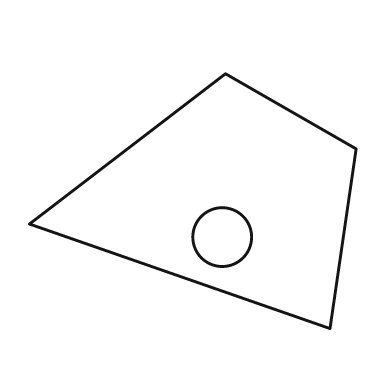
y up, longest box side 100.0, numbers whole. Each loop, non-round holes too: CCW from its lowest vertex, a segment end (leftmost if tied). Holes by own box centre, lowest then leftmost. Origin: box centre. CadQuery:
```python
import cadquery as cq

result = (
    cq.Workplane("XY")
    .moveTo(42.0, -39.0)
    .lineTo(50.0, 16.0)
    .lineTo(10.0, 39.0)
    .lineTo(-50.0, -7.0)
    .close()
    .moveTo(9.0, -11.0)
    .circle(9.0)
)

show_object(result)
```